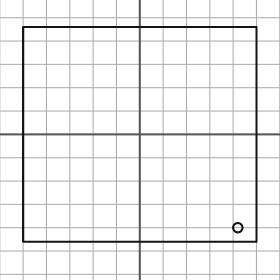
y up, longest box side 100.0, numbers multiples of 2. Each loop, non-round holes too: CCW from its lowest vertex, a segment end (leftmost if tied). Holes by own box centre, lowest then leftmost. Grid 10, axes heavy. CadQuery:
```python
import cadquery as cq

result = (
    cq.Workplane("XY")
    .moveTo(-50.0, -46.0)
    .lineTo(50.0, -46.0)
    .lineTo(50.0, 46.0)
    .lineTo(-50.0, 46.0)
    .close()
    .moveTo(42.0, -40.0)
    .circle(2.0)
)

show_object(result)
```